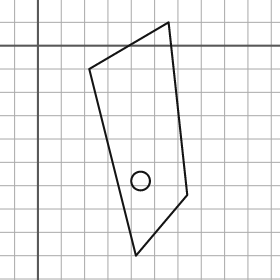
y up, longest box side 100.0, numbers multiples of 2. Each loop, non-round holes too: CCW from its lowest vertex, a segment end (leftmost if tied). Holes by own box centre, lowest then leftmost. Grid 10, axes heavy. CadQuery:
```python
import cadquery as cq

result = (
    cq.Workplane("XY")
    .moveTo(42.0, -90.0)
    .lineTo(64.0, -64.0)
    .lineTo(56.0, 10.0)
    .lineTo(22.0, -10.0)
    .close()
    .moveTo(44.0, -58.0)
    .circle(4.0)
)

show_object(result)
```